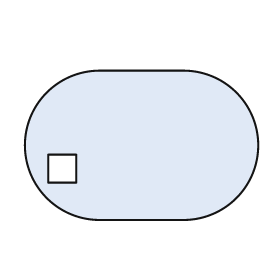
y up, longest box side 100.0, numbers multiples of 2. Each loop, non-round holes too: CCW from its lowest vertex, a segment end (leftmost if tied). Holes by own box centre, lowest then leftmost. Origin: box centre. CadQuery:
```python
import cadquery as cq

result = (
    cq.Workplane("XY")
    .moveTo(-18.0, -32.0)
    .lineTo(18.0, -32.0)
    .threePointArc((50.0, 0.0), (18.0, 32.0))
    .lineTo(-18.0, 32.0)
    .threePointArc((-50.0, 0.0), (-18.0, -32.0))
    .close()
    .moveTo(-40.0, -16.0)
    .lineTo(-28.0, -16.0)
    .lineTo(-28.0, -4.0)
    .lineTo(-40.0, -4.0)
    .close()
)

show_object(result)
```